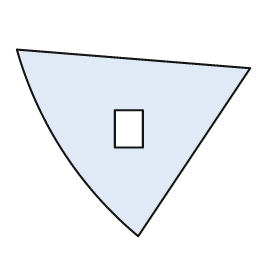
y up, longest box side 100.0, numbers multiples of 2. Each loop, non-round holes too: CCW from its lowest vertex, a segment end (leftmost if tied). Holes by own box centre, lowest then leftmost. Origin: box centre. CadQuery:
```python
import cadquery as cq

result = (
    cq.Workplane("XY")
    .moveTo(2.0, -40.0)
    .lineTo(50.0, 32.0)
    .lineTo(-50.0, 40.0)
    .threePointArc((-30.0, -4.0), (2.0, -40.0))
    .close()
    .moveTo(-8.0, -2.0)
    .lineTo(4.0, -2.0)
    .lineTo(4.0, 14.0)
    .lineTo(-8.0, 14.0)
    .close()
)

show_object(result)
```